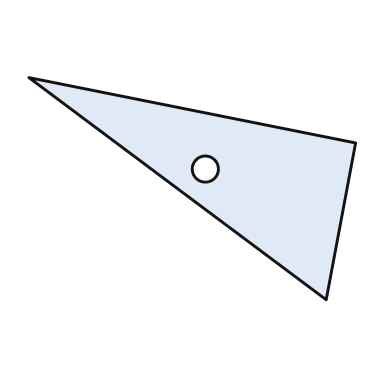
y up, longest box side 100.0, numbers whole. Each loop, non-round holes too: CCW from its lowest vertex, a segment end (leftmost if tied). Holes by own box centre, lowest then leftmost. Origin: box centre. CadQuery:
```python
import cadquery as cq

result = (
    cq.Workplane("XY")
    .moveTo(41.0, -34.0)
    .lineTo(50.0, 14.0)
    .lineTo(-50.0, 34.0)
    .close()
    .moveTo(4.0, 6.0)
    .circle(4.0)
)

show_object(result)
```